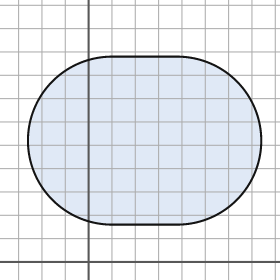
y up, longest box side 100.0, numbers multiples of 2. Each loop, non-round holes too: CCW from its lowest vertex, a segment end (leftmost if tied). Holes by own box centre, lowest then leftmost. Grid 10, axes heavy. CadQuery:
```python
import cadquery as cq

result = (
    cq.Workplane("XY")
    .moveTo(10.0, 16.0)
    .lineTo(38.0, 16.0)
    .threePointArc((74.0, 52.0), (38.0, 88.0))
    .lineTo(10.0, 88.0)
    .threePointArc((-26.0, 52.0), (10.0, 16.0))
    .close()
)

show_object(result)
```